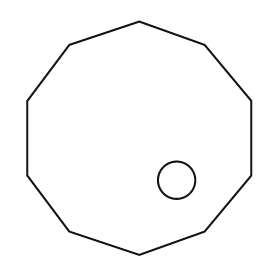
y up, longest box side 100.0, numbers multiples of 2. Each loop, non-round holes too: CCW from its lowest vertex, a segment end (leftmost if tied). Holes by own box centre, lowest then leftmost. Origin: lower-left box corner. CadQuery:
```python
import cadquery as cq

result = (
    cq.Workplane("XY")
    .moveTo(48.0, 0.0)
    .lineTo(76.0, 10.0)
    .lineTo(96.0, 34.0)
    .lineTo(96.0, 66.0)
    .lineTo(76.0, 90.0)
    .lineTo(48.0, 100.0)
    .lineTo(18.0, 90.0)
    .lineTo(0.0, 66.0)
    .lineTo(0.0, 34.0)
    .lineTo(18.0, 10.0)
    .close()
    .moveTo(64.0, 32.0)
    .circle(8.0)
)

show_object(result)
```